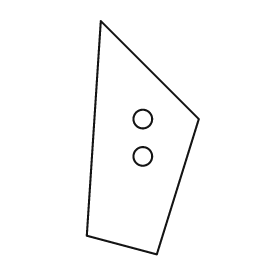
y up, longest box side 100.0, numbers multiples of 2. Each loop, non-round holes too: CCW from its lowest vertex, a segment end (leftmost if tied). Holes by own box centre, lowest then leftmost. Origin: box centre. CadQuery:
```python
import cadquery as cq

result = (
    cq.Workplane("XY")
    .moveTo(6.0, -50.0)
    .lineTo(24.0, 8.0)
    .lineTo(-18.0, 50.0)
    .lineTo(-24.0, -42.0)
    .close()
    .moveTo(0.0, -8.0)
    .circle(4.0)
    .moveTo(0.0, 8.0)
    .circle(4.0)
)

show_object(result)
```